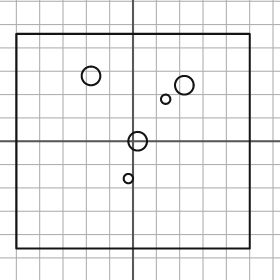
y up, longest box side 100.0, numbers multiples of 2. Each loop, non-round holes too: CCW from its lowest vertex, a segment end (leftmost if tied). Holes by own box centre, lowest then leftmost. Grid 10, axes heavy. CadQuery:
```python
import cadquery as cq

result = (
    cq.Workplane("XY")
    .moveTo(-50.0, -46.0)
    .lineTo(50.0, -46.0)
    .lineTo(50.0, 46.0)
    .lineTo(-50.0, 46.0)
    .close()
    .moveTo(-2.0, -16.0)
    .circle(2.0)
    .moveTo(2.0, 0.0)
    .circle(4.0)
    .moveTo(14.0, 18.0)
    .circle(2.0)
    .moveTo(22.0, 24.0)
    .circle(4.0)
    .moveTo(-18.0, 28.0)
    .circle(4.0)
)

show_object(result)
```